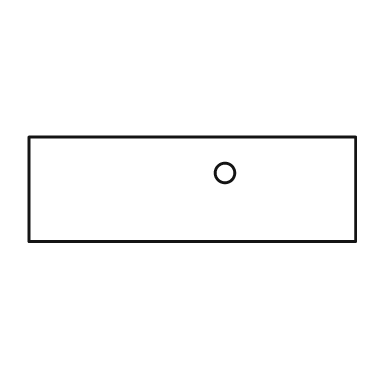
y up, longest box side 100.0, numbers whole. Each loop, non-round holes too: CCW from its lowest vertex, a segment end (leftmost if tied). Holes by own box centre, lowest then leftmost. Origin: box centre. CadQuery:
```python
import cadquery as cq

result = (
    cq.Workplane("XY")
    .moveTo(-50.0, -16.0)
    .lineTo(50.0, -16.0)
    .lineTo(50.0, 16.0)
    .lineTo(-50.0, 16.0)
    .close()
    .moveTo(10.0, 5.0)
    .circle(3.0)
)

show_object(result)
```